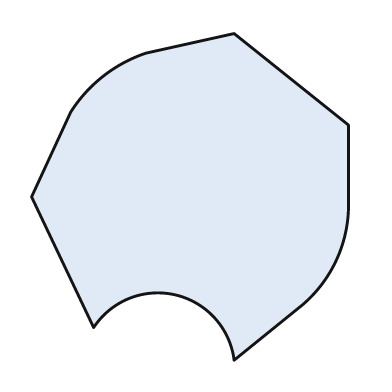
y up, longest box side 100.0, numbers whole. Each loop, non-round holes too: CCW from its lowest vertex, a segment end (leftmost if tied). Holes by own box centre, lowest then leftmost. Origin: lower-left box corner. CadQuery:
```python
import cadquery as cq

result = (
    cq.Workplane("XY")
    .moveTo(62.0, 0.0)
    .lineTo(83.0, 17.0)
    .threePointArc((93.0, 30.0), (97.0, 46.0))
    .lineTo(97.0, 72.0)
    .lineTo(62.0, 100.0)
    .lineTo(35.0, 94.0)
    .threePointArc((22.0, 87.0), (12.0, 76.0))
    .lineTo(0.0, 50.0)
    .lineTo(19.0, 10.0)
    .threePointArc((44.0, 20.0), (62.0, 0.0))
    .close()
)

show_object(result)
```